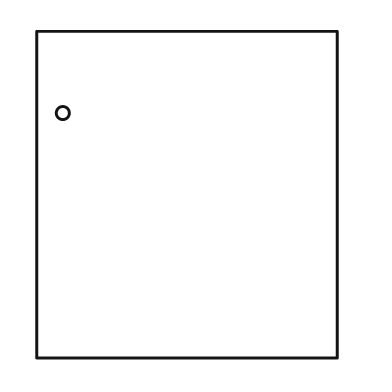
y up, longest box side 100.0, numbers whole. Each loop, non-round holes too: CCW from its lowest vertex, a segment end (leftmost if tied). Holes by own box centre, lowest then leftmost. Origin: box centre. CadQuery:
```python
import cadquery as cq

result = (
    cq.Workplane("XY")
    .moveTo(-46.0, -50.0)
    .lineTo(46.0, -50.0)
    .lineTo(46.0, 50.0)
    .lineTo(-46.0, 50.0)
    .close()
    .moveTo(-38.0, 25.0)
    .circle(2.0)
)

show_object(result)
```